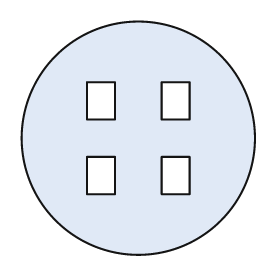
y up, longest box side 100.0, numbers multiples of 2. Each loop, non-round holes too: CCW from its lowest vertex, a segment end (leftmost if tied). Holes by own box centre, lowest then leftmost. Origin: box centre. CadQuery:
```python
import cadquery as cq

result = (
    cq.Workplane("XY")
    .moveTo(0.0, 0.0)
    .circle(50.0)
    .moveTo(-22.0, -24.0)
    .lineTo(-10.0, -24.0)
    .lineTo(-10.0, -8.0)
    .lineTo(-22.0, -8.0)
    .close()
    .moveTo(10.0, -24.0)
    .lineTo(22.0, -24.0)
    .lineTo(22.0, -8.0)
    .lineTo(10.0, -8.0)
    .close()
    .moveTo(-22.0, 8.0)
    .lineTo(-10.0, 8.0)
    .lineTo(-10.0, 24.0)
    .lineTo(-22.0, 24.0)
    .close()
    .moveTo(10.0, 8.0)
    .lineTo(22.0, 8.0)
    .lineTo(22.0, 24.0)
    .lineTo(10.0, 24.0)
    .close()
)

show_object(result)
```